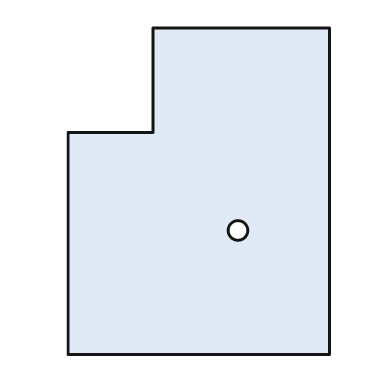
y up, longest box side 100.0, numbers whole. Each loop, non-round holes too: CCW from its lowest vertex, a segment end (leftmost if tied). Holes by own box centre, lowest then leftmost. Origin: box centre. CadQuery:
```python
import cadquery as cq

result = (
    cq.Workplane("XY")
    .moveTo(-40.0, -50.0)
    .lineTo(40.0, -50.0)
    .lineTo(40.0, 50.0)
    .lineTo(-14.0, 50.0)
    .lineTo(-14.0, 18.0)
    .lineTo(-40.0, 18.0)
    .close()
    .moveTo(12.0, -12.0)
    .circle(3.0)
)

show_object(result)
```